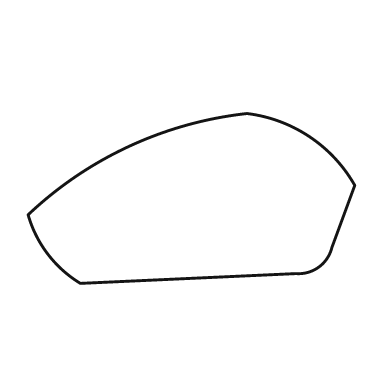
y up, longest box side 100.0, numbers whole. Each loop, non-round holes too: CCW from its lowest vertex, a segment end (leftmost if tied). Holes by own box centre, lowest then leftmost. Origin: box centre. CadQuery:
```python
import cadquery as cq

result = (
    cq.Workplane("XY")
    .moveTo(-34.0, -26.0)
    .lineTo(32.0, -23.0)
    .threePointArc((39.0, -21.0), (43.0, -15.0))
    .lineTo(50.0, 4.0)
    .threePointArc((36.0, 19.0), (17.0, 26.0))
    .threePointArc((-19.0, 16.0), (-50.0, -5.0))
    .threePointArc((-44.0, -17.0), (-34.0, -26.0))
    .close()
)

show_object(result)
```